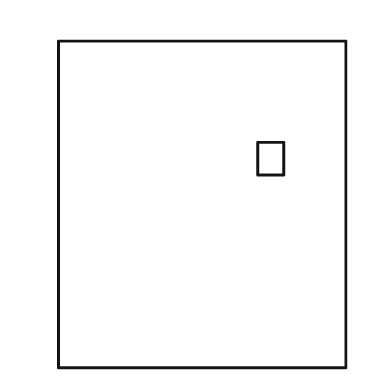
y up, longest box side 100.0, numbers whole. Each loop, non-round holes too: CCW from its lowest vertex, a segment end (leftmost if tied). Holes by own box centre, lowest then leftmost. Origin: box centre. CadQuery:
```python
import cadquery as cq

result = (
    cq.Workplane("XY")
    .moveTo(-44.0, -50.0)
    .lineTo(44.0, -50.0)
    .lineTo(44.0, 50.0)
    .lineTo(-44.0, 50.0)
    .close()
    .moveTo(17.0, 9.0)
    .lineTo(25.0, 9.0)
    .lineTo(25.0, 19.0)
    .lineTo(17.0, 19.0)
    .close()
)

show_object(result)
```